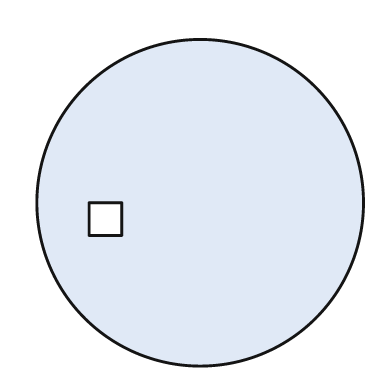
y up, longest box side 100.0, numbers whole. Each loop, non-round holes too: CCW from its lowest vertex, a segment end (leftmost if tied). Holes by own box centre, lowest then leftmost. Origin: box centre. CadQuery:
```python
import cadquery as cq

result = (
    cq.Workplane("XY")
    .moveTo(0.0, 0.0)
    .circle(50.0)
    .moveTo(-34.0, -10.0)
    .lineTo(-24.0, -10.0)
    .lineTo(-24.0, 0.0)
    .lineTo(-34.0, 0.0)
    .close()
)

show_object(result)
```